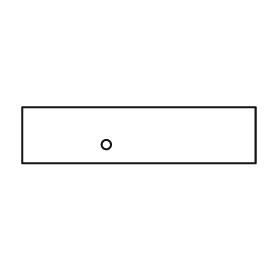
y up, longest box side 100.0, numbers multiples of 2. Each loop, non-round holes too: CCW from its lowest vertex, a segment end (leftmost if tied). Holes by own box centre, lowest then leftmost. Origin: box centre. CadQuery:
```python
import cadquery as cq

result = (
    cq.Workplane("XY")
    .moveTo(-50.0, -12.0)
    .lineTo(50.0, -12.0)
    .lineTo(50.0, 12.0)
    .lineTo(-50.0, 12.0)
    .close()
    .moveTo(-14.0, -4.0)
    .circle(2.0)
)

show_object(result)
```